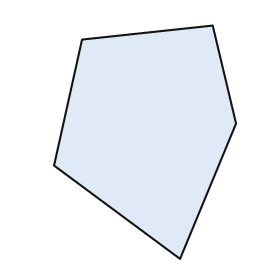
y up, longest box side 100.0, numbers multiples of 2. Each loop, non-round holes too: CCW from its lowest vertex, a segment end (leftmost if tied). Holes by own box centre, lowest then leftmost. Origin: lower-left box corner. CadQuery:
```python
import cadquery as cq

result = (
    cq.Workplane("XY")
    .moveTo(54.0, 0.0)
    .lineTo(78.0, 58.0)
    .lineTo(68.0, 100.0)
    .lineTo(12.0, 94.0)
    .lineTo(0.0, 40.0)
    .close()
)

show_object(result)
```